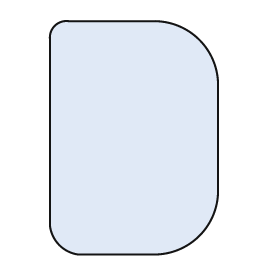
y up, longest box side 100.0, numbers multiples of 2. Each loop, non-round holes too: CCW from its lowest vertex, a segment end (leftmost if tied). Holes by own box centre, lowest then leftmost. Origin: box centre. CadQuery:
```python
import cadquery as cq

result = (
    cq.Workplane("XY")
    .moveTo(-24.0, -50.0)
    .lineTo(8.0, -50.0)
    .threePointArc((28.0, -42.0), (36.0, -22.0))
    .lineTo(36.0, 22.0)
    .threePointArc((28.0, 42.0), (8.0, 50.0))
    .lineTo(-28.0, 50.0)
    .threePointArc((-34.0, 48.0), (-36.0, 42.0))
    .lineTo(-36.0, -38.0)
    .threePointArc((-32.0, -46.0), (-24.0, -50.0))
    .close()
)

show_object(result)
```